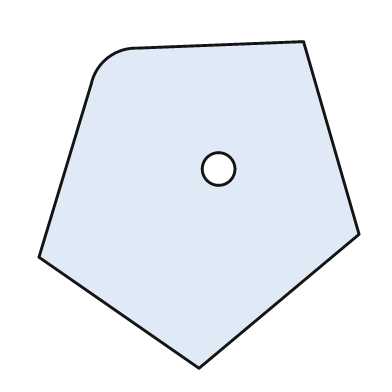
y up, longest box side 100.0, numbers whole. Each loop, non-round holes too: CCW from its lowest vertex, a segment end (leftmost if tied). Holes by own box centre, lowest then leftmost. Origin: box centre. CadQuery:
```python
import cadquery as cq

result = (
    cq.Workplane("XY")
    .moveTo(0.0, -50.0)
    .lineTo(49.0, -9.0)
    .lineTo(32.0, 50.0)
    .lineTo(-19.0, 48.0)
    .threePointArc((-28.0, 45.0), (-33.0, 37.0))
    .lineTo(-49.0, -16.0)
    .close()
    .moveTo(6.0, 11.0)
    .circle(5.0)
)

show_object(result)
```